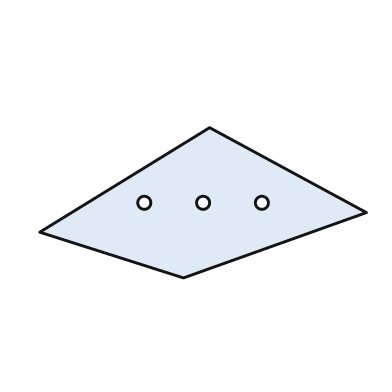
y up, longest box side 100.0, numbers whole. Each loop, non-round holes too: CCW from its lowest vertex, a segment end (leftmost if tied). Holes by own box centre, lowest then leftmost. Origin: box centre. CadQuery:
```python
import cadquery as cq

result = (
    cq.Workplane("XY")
    .moveTo(-6.0, -23.0)
    .lineTo(50.0, -3.0)
    .lineTo(2.0, 23.0)
    .lineTo(-50.0, -9.0)
    .close()
    .moveTo(-18.0, 0.0)
    .circle(2.0)
    .moveTo(0.0, 0.0)
    .circle(2.0)
    .moveTo(18.0, 0.0)
    .circle(2.0)
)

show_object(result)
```